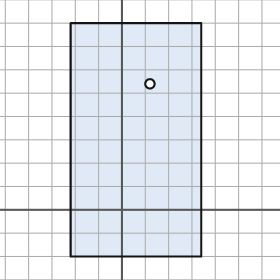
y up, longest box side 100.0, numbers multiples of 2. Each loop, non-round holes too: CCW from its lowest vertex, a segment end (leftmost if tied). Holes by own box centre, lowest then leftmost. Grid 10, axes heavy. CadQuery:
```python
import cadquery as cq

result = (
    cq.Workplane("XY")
    .moveTo(-22.0, -20.0)
    .lineTo(34.0, -20.0)
    .lineTo(34.0, 80.0)
    .lineTo(-22.0, 80.0)
    .close()
    .moveTo(12.0, 54.0)
    .circle(2.0)
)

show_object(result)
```